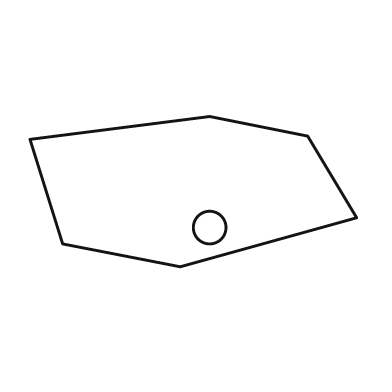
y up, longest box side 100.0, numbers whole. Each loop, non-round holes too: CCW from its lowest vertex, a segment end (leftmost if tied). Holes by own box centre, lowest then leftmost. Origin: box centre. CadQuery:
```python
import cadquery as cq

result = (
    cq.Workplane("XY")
    .moveTo(-4.0, -23.0)
    .lineTo(50.0, -8.0)
    .lineTo(35.0, 17.0)
    .lineTo(5.0, 23.0)
    .lineTo(-50.0, 16.0)
    .lineTo(-40.0, -16.0)
    .close()
    .moveTo(5.0, -11.0)
    .circle(5.0)
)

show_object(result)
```